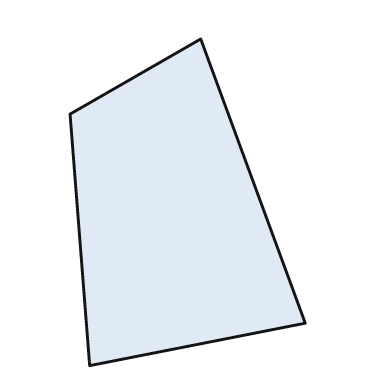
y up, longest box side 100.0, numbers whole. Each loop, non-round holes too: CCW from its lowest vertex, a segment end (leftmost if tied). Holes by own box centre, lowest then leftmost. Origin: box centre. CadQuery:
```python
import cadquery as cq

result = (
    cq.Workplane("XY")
    .moveTo(-30.0, -50.0)
    .lineTo(36.0, -37.0)
    .lineTo(4.0, 50.0)
    .lineTo(-36.0, 27.0)
    .close()
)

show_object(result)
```